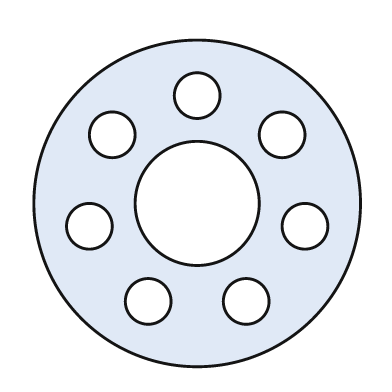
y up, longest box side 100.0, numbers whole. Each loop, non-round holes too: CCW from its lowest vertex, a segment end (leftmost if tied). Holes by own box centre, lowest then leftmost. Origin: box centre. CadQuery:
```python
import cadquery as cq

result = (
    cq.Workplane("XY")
    .moveTo(0.0, 0.0)
    .circle(50.0)
    .moveTo(-15.0, -30.0)
    .circle(7.0)
    .moveTo(15.0, -30.0)
    .circle(7.0)
    .moveTo(-33.0, -7.0)
    .circle(7.0)
    .moveTo(33.0, -7.0)
    .circle(7.0)
    .moveTo(0.0, 0.0)
    .circle(19.0)
    .moveTo(-26.0, 21.0)
    .circle(7.0)
    .moveTo(26.0, 21.0)
    .circle(7.0)
    .moveTo(0.0, 33.0)
    .circle(7.0)
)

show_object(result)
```